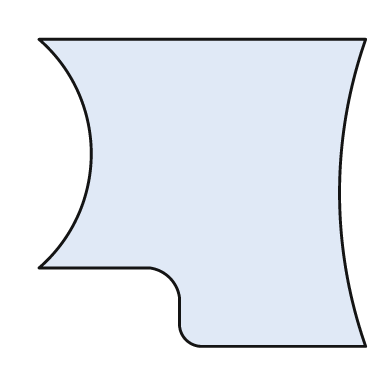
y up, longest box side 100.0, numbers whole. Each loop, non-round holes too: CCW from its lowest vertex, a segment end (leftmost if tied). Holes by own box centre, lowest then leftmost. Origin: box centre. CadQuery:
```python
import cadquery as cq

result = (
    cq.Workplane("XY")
    .moveTo(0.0, -47.0)
    .lineTo(50.0, -47.0)
    .threePointArc((42.0, 0.0), (50.0, 47.0))
    .lineTo(-50.0, 47.0)
    .threePointArc((-34.0, 12.0), (-50.0, -23.0))
    .lineTo(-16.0, -23.0)
    .threePointArc((-10.0, -26.0), (-7.0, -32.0))
    .lineTo(-7.0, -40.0)
    .threePointArc((-5.0, -45.0), (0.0, -47.0))
    .close()
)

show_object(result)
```